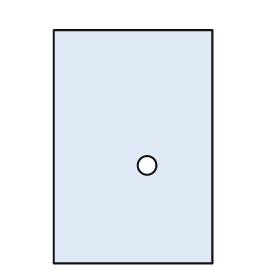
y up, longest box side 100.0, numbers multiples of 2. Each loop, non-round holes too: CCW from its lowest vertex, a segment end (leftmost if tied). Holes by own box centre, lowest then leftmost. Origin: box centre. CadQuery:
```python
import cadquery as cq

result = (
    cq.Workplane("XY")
    .moveTo(-34.0, -50.0)
    .lineTo(34.0, -50.0)
    .lineTo(34.0, 50.0)
    .lineTo(-34.0, 50.0)
    .close()
    .moveTo(6.0, -8.0)
    .circle(4.0)
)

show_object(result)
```